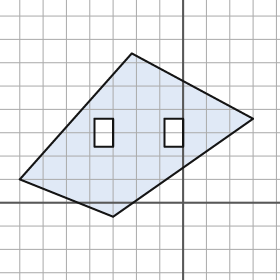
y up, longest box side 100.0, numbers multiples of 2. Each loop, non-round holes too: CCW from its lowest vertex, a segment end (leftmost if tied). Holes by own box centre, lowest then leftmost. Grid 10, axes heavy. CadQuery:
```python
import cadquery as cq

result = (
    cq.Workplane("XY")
    .moveTo(-30.0, -6.0)
    .lineTo(30.0, 36.0)
    .lineTo(-22.0, 64.0)
    .lineTo(-70.0, 10.0)
    .close()
    .moveTo(-38.0, 24.0)
    .lineTo(-30.0, 24.0)
    .lineTo(-30.0, 36.0)
    .lineTo(-38.0, 36.0)
    .close()
    .moveTo(-8.0, 24.0)
    .lineTo(0.0, 24.0)
    .lineTo(0.0, 36.0)
    .lineTo(-8.0, 36.0)
    .close()
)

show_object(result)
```